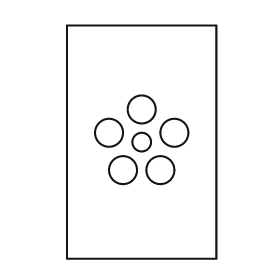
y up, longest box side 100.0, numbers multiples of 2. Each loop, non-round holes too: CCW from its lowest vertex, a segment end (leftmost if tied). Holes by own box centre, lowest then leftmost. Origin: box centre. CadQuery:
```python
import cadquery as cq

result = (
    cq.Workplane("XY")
    .moveTo(-32.0, -50.0)
    .lineTo(32.0, -50.0)
    .lineTo(32.0, 50.0)
    .lineTo(-32.0, 50.0)
    .close()
    .moveTo(-8.0, -12.0)
    .circle(6.0)
    .moveTo(8.0, -12.0)
    .circle(6.0)
    .moveTo(0.0, 0.0)
    .circle(4.0)
    .moveTo(-14.0, 4.0)
    .circle(6.0)
    .moveTo(14.0, 4.0)
    .circle(6.0)
    .moveTo(0.0, 14.0)
    .circle(6.0)
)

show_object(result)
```